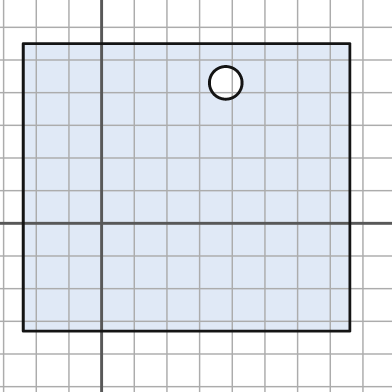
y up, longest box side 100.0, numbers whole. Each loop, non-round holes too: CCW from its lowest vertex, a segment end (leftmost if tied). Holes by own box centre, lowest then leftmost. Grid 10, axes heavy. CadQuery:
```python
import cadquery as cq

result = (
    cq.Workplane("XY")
    .moveTo(-24.0, -33.0)
    .lineTo(76.0, -33.0)
    .lineTo(76.0, 55.0)
    .lineTo(-24.0, 55.0)
    .close()
    .moveTo(38.0, 43.0)
    .circle(5.0)
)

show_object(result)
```